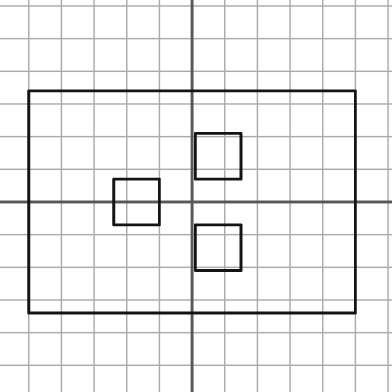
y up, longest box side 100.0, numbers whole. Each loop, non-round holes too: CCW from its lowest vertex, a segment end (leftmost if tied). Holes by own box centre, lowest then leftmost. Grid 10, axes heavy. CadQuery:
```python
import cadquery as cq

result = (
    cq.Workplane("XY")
    .moveTo(-50.0, -34.0)
    .lineTo(50.0, -34.0)
    .lineTo(50.0, 34.0)
    .lineTo(-50.0, 34.0)
    .close()
    .moveTo(1.0, -21.0)
    .lineTo(15.0, -21.0)
    .lineTo(15.0, -7.0)
    .lineTo(1.0, -7.0)
    .close()
    .moveTo(-24.0, -7.0)
    .lineTo(-10.0, -7.0)
    .lineTo(-10.0, 7.0)
    .lineTo(-24.0, 7.0)
    .close()
    .moveTo(1.0, 7.0)
    .lineTo(15.0, 7.0)
    .lineTo(15.0, 21.0)
    .lineTo(1.0, 21.0)
    .close()
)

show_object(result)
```